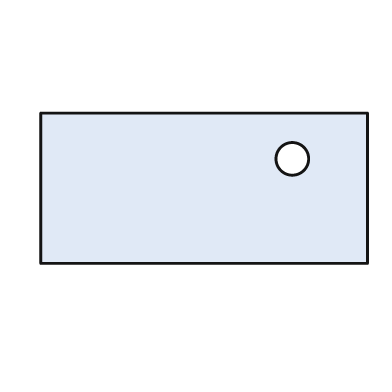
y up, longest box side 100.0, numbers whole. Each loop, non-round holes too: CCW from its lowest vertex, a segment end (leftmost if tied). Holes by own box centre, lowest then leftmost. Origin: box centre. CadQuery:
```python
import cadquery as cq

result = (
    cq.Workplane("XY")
    .moveTo(-50.0, -23.0)
    .lineTo(50.0, -23.0)
    .lineTo(50.0, 23.0)
    .lineTo(-50.0, 23.0)
    .close()
    .moveTo(27.0, 9.0)
    .circle(5.0)
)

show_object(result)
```